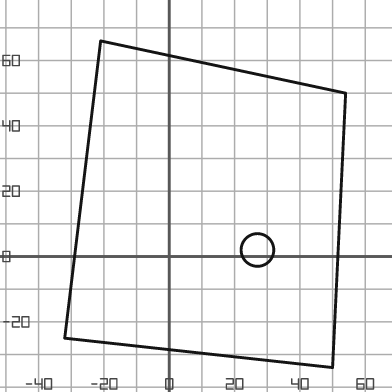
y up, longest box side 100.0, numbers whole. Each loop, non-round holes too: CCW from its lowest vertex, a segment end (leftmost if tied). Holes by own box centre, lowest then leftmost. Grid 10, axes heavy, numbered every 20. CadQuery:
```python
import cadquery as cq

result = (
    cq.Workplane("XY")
    .moveTo(50.0, -34.0)
    .lineTo(54.0, 50.0)
    .lineTo(-21.0, 66.0)
    .lineTo(-32.0, -25.0)
    .close()
    .moveTo(27.0, 2.0)
    .circle(5.0)
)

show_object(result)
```